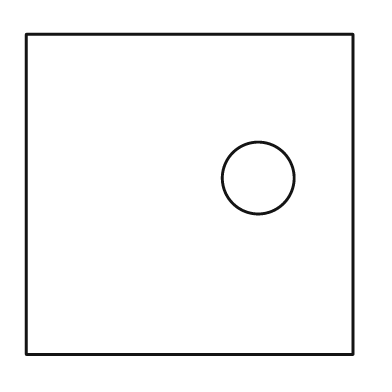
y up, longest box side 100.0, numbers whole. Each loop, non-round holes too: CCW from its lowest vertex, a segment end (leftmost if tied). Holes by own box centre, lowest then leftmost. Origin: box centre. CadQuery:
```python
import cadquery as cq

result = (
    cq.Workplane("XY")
    .moveTo(-50.0, -49.0)
    .lineTo(50.0, -49.0)
    .lineTo(50.0, 49.0)
    .lineTo(-50.0, 49.0)
    .close()
    .moveTo(21.0, 5.0)
    .circle(11.0)
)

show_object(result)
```